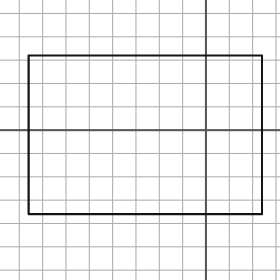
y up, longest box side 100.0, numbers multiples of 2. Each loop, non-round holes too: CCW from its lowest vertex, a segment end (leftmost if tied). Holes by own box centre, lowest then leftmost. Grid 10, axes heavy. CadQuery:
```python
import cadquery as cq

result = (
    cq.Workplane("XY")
    .moveTo(-76.0, -36.0)
    .lineTo(24.0, -36.0)
    .lineTo(24.0, 32.0)
    .lineTo(-76.0, 32.0)
    .close()
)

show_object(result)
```